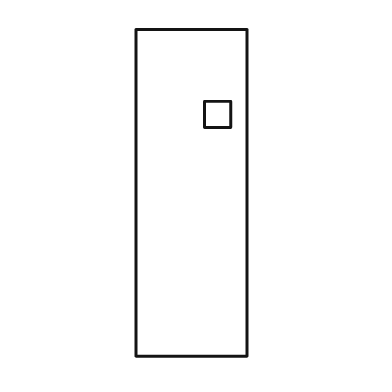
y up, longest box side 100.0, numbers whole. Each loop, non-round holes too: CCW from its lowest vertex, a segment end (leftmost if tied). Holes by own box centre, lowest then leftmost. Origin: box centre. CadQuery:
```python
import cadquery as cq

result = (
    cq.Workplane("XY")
    .moveTo(-17.0, -50.0)
    .lineTo(17.0, -50.0)
    .lineTo(17.0, 50.0)
    .lineTo(-17.0, 50.0)
    .close()
    .moveTo(4.0, 20.0)
    .lineTo(12.0, 20.0)
    .lineTo(12.0, 28.0)
    .lineTo(4.0, 28.0)
    .close()
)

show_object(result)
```